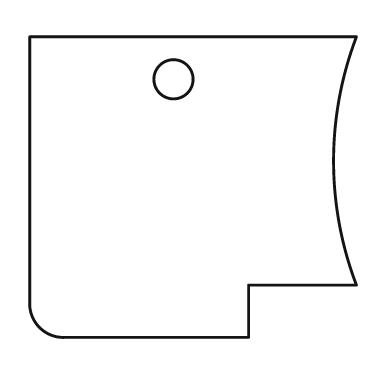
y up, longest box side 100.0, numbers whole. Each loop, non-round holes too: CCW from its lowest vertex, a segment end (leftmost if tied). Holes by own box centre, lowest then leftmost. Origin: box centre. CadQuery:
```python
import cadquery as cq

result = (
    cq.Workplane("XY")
    .moveTo(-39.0, -46.0)
    .lineTo(17.0, -46.0)
    .lineTo(17.0, -30.0)
    .lineTo(50.0, -30.0)
    .threePointArc((43.0, 8.0), (50.0, 46.0))
    .lineTo(-50.0, 46.0)
    .lineTo(-50.0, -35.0)
    .threePointArc((-47.0, -43.0), (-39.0, -46.0))
    .close()
    .moveTo(-6.0, 33.0)
    .circle(6.0)
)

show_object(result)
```